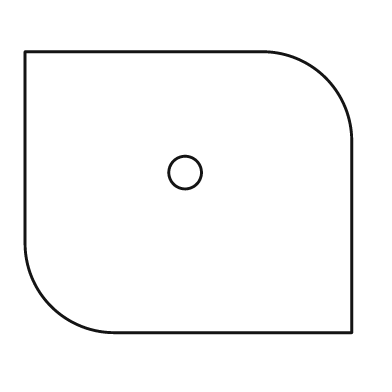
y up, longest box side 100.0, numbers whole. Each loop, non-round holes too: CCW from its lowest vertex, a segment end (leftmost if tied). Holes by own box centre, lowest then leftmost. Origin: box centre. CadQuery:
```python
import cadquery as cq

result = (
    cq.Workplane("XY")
    .moveTo(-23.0, -43.0)
    .lineTo(50.0, -43.0)
    .lineTo(50.0, 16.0)
    .threePointArc((42.0, 35.0), (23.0, 43.0))
    .lineTo(-50.0, 43.0)
    .lineTo(-50.0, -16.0)
    .threePointArc((-42.0, -35.0), (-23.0, -43.0))
    .close()
    .moveTo(-1.0, 6.0)
    .circle(5.0)
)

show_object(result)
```